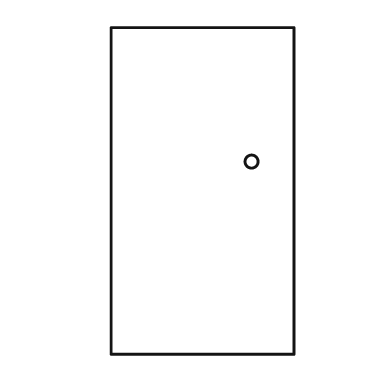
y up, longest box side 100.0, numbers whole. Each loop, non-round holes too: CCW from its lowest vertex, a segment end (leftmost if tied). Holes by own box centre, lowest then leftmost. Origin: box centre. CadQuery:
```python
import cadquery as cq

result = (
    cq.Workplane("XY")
    .moveTo(-28.0, -50.0)
    .lineTo(28.0, -50.0)
    .lineTo(28.0, 50.0)
    .lineTo(-28.0, 50.0)
    .close()
    .moveTo(15.0, 9.0)
    .circle(2.0)
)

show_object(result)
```